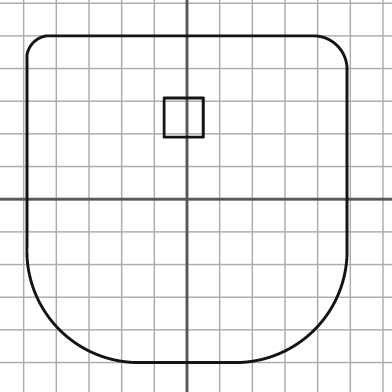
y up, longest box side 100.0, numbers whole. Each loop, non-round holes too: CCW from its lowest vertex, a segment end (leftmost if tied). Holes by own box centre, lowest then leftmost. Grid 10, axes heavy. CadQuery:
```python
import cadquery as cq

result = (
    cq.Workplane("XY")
    .moveTo(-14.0, -50.0)
    .lineTo(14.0, -50.0)
    .threePointArc((39.0, -40.0), (49.0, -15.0))
    .lineTo(49.0, 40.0)
    .threePointArc((46.0, 47.0), (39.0, 50.0))
    .lineTo(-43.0, 50.0)
    .threePointArc((-47.0, 48.0), (-49.0, 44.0))
    .lineTo(-49.0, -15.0)
    .threePointArc((-39.0, -40.0), (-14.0, -50.0))
    .close()
    .moveTo(-7.0, 19.0)
    .lineTo(5.0, 19.0)
    .lineTo(5.0, 31.0)
    .lineTo(-7.0, 31.0)
    .close()
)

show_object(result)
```